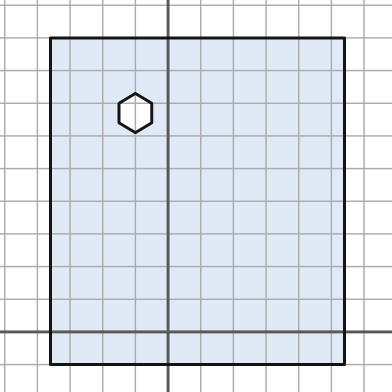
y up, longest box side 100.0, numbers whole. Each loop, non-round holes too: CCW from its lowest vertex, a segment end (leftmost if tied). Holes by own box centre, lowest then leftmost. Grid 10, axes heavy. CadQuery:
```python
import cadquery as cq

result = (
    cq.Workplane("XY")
    .moveTo(-36.0, -10.0)
    .lineTo(54.0, -10.0)
    .lineTo(54.0, 90.0)
    .lineTo(-36.0, 90.0)
    .close()
    .moveTo(-10.0, 61.0)
    .lineTo(-5.0, 64.0)
    .lineTo(-5.0, 70.0)
    .lineTo(-10.0, 73.0)
    .lineTo(-15.0, 70.0)
    .lineTo(-15.0, 64.0)
    .close()
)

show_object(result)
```